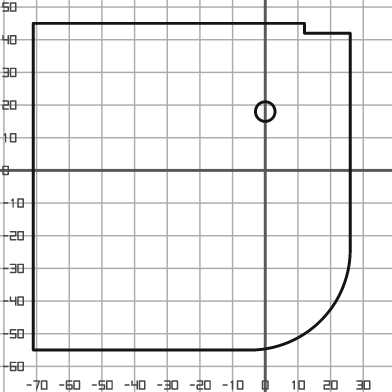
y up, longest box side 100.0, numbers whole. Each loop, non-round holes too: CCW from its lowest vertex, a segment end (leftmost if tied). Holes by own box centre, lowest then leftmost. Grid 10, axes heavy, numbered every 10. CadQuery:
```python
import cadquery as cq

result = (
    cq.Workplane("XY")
    .moveTo(-71.0, -55.0)
    .lineTo(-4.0, -55.0)
    .threePointArc((17.0, -46.0), (26.0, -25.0))
    .lineTo(26.0, 42.0)
    .lineTo(12.0, 42.0)
    .lineTo(12.0, 45.0)
    .lineTo(-71.0, 45.0)
    .close()
    .moveTo(0.0, 18.0)
    .circle(3.0)
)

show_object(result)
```